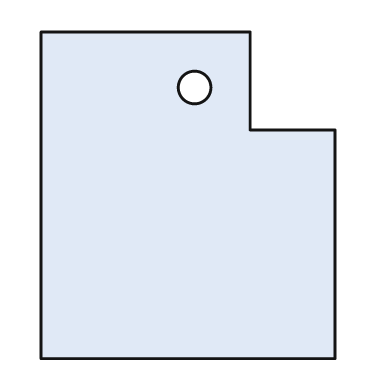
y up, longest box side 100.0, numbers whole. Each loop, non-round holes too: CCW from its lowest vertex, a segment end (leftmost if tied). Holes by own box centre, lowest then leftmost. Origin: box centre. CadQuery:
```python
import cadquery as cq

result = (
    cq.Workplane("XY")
    .moveTo(-45.0, -50.0)
    .lineTo(45.0, -50.0)
    .lineTo(45.0, 20.0)
    .lineTo(19.0, 20.0)
    .lineTo(19.0, 50.0)
    .lineTo(-45.0, 50.0)
    .close()
    .moveTo(2.0, 33.0)
    .circle(5.0)
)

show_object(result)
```